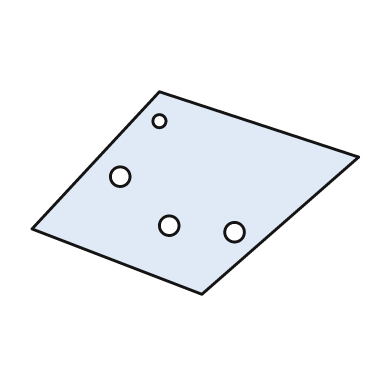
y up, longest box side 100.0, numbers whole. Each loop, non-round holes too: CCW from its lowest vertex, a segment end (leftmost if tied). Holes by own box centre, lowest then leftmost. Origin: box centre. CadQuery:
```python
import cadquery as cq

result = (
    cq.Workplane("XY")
    .moveTo(2.0, -31.0)
    .lineTo(50.0, 11.0)
    .lineTo(-11.0, 31.0)
    .lineTo(-50.0, -11.0)
    .close()
    .moveTo(12.0, -12.0)
    .circle(3.0)
    .moveTo(-8.0, -10.0)
    .circle(3.0)
    .moveTo(-23.0, 5.0)
    .circle(3.0)
    .moveTo(-11.0, 22.0)
    .circle(2.0)
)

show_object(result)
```